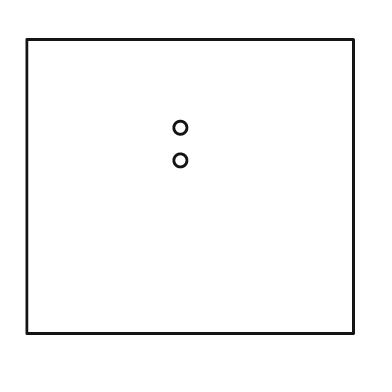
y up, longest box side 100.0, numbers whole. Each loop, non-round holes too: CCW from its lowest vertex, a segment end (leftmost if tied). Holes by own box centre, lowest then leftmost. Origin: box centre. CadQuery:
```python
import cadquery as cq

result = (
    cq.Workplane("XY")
    .moveTo(-50.0, -45.0)
    .lineTo(50.0, -45.0)
    .lineTo(50.0, 45.0)
    .lineTo(-50.0, 45.0)
    .close()
    .moveTo(-3.0, 8.0)
    .circle(2.0)
    .moveTo(-3.0, 18.0)
    .circle(2.0)
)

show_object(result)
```